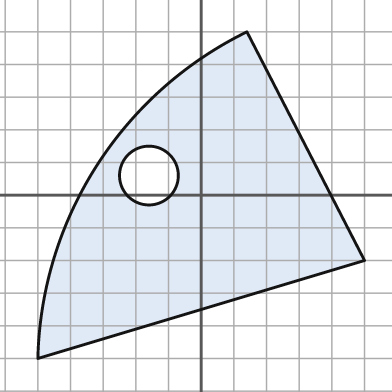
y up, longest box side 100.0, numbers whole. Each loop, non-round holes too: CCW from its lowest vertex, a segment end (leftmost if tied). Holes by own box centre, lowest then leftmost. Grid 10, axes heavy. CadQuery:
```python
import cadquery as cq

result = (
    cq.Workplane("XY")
    .moveTo(-50.0, -50.0)
    .lineTo(50.0, -20.0)
    .lineTo(14.0, 50.0)
    .threePointArc((-32.0, 9.0), (-50.0, -50.0))
    .close()
    .moveTo(-16.0, 6.0)
    .circle(9.0)
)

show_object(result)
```